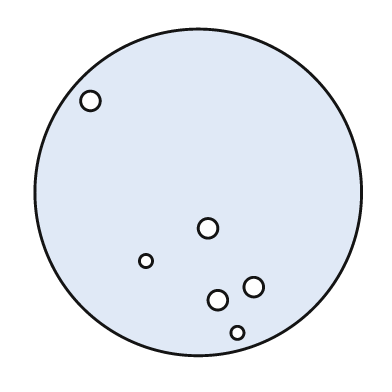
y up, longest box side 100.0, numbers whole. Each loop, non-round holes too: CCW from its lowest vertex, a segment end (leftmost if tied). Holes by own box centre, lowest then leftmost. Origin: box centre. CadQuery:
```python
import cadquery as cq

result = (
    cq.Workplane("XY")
    .moveTo(0.0, 0.0)
    .circle(50.0)
    .moveTo(12.0, -43.0)
    .circle(2.0)
    .moveTo(6.0, -33.0)
    .circle(3.0)
    .moveTo(17.0, -29.0)
    .circle(3.0)
    .moveTo(-16.0, -21.0)
    .circle(2.0)
    .moveTo(3.0, -11.0)
    .circle(3.0)
    .moveTo(-33.0, 28.0)
    .circle(3.0)
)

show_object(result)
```